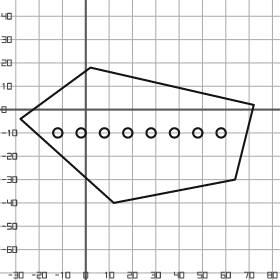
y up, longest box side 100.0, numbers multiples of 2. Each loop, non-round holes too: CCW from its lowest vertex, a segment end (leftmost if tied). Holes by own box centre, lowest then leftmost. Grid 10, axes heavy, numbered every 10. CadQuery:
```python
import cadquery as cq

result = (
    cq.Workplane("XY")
    .moveTo(12.0, -40.0)
    .lineTo(64.0, -30.0)
    .lineTo(72.0, 2.0)
    .lineTo(2.0, 18.0)
    .lineTo(-28.0, -4.0)
    .close()
    .moveTo(-12.0, -10.0)
    .circle(2.0)
    .moveTo(-2.0, -10.0)
    .circle(2.0)
    .moveTo(8.0, -10.0)
    .circle(2.0)
    .moveTo(18.0, -10.0)
    .circle(2.0)
    .moveTo(28.0, -10.0)
    .circle(2.0)
    .moveTo(38.0, -10.0)
    .circle(2.0)
    .moveTo(48.0, -10.0)
    .circle(2.0)
    .moveTo(58.0, -10.0)
    .circle(2.0)
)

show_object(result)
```